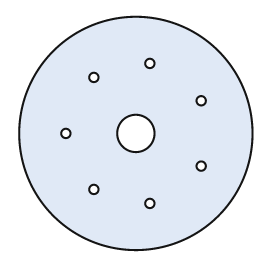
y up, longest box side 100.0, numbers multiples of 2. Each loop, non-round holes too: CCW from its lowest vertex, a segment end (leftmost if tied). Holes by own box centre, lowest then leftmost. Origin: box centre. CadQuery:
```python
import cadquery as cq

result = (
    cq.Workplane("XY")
    .moveTo(0.0, 0.0)
    .circle(50.0)
    .moveTo(6.0, -30.0)
    .circle(2.0)
    .moveTo(-18.0, -24.0)
    .circle(2.0)
    .moveTo(28.0, -14.0)
    .circle(2.0)
    .moveTo(-30.0, 0.0)
    .circle(2.0)
    .moveTo(0.0, 0.0)
    .circle(8.0)
    .moveTo(28.0, 14.0)
    .circle(2.0)
    .moveTo(-18.0, 24.0)
    .circle(2.0)
    .moveTo(6.0, 30.0)
    .circle(2.0)
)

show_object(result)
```